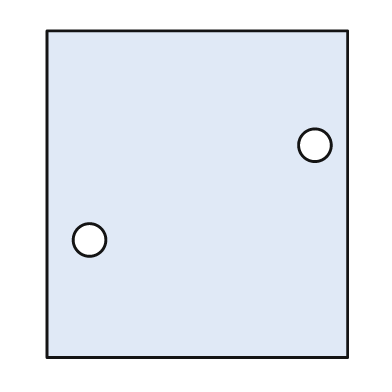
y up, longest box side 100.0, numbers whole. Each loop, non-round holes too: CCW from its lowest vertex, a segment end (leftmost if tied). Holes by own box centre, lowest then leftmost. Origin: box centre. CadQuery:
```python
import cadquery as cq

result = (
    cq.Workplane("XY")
    .moveTo(-46.0, -50.0)
    .lineTo(46.0, -50.0)
    .lineTo(46.0, 50.0)
    .lineTo(-46.0, 50.0)
    .close()
    .moveTo(-33.0, -14.0)
    .circle(5.0)
    .moveTo(36.0, 15.0)
    .circle(5.0)
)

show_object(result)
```